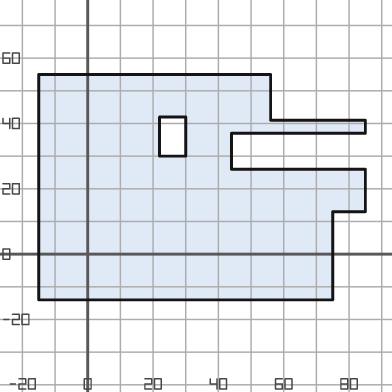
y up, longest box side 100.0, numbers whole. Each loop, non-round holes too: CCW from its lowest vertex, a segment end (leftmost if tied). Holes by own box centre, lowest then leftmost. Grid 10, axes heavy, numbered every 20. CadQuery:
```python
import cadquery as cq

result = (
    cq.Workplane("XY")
    .moveTo(-15.0, -14.0)
    .lineTo(75.0, -14.0)
    .lineTo(75.0, 13.0)
    .lineTo(85.0, 13.0)
    .lineTo(85.0, 26.0)
    .lineTo(44.0, 26.0)
    .lineTo(44.0, 37.0)
    .lineTo(85.0, 37.0)
    .lineTo(85.0, 41.0)
    .lineTo(56.0, 41.0)
    .lineTo(56.0, 55.0)
    .lineTo(-15.0, 55.0)
    .close()
    .moveTo(22.0, 30.0)
    .lineTo(30.0, 30.0)
    .lineTo(30.0, 42.0)
    .lineTo(22.0, 42.0)
    .close()
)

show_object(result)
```